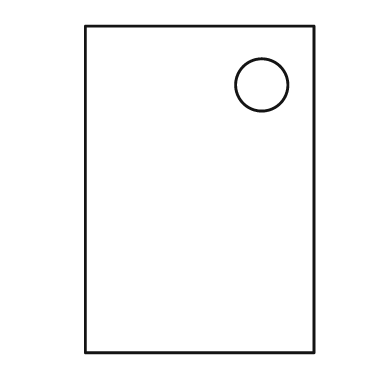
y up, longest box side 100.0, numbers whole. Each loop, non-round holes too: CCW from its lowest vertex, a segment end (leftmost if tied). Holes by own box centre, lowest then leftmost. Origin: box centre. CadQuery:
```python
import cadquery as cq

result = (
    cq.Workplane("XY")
    .moveTo(-35.0, -50.0)
    .lineTo(35.0, -50.0)
    .lineTo(35.0, 50.0)
    .lineTo(-35.0, 50.0)
    .close()
    .moveTo(19.0, 32.0)
    .circle(8.0)
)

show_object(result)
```